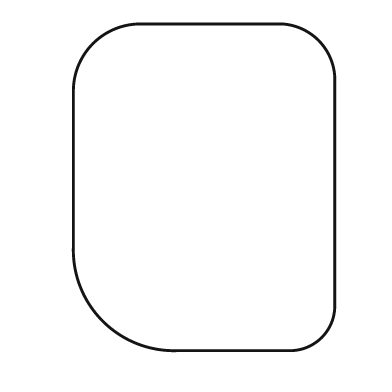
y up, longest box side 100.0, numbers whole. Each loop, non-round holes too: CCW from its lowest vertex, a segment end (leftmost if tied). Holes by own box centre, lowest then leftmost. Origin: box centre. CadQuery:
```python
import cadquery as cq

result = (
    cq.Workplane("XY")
    .moveTo(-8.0, -50.0)
    .lineTo(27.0, -50.0)
    .threePointArc((36.0, -46.0), (40.0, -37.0))
    .lineTo(40.0, 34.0)
    .threePointArc((35.0, 45.0), (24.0, 50.0))
    .lineTo(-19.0, 50.0)
    .threePointArc((-34.0, 44.0), (-40.0, 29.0))
    .lineTo(-40.0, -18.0)
    .threePointArc((-31.0, -41.0), (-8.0, -50.0))
    .close()
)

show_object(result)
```